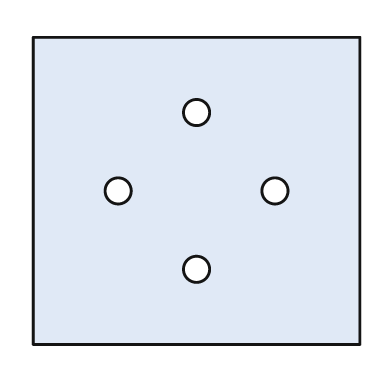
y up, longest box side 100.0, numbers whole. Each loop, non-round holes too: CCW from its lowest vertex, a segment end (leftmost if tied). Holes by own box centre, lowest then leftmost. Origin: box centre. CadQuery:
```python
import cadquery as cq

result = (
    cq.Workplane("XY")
    .moveTo(-50.0, -47.0)
    .lineTo(50.0, -47.0)
    .lineTo(50.0, 47.0)
    .lineTo(-50.0, 47.0)
    .close()
    .moveTo(0.0, -24.0)
    .circle(4.0)
    .moveTo(-24.0, 0.0)
    .circle(4.0)
    .moveTo(24.0, 0.0)
    .circle(4.0)
    .moveTo(0.0, 24.0)
    .circle(4.0)
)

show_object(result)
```